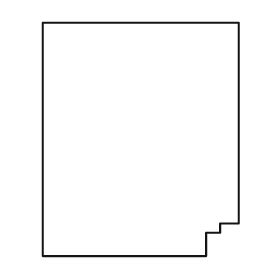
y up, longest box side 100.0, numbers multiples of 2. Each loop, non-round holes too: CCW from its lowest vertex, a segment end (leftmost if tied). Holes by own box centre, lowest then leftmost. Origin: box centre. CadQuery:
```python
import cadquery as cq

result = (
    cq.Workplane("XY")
    .moveTo(-42.0, -50.0)
    .lineTo(28.0, -50.0)
    .lineTo(28.0, -40.0)
    .lineTo(34.0, -40.0)
    .lineTo(34.0, -36.0)
    .lineTo(42.0, -36.0)
    .lineTo(42.0, 50.0)
    .lineTo(-42.0, 50.0)
    .close()
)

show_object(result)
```